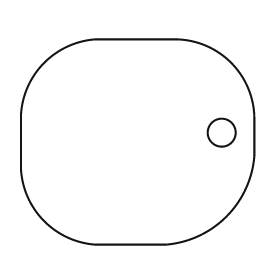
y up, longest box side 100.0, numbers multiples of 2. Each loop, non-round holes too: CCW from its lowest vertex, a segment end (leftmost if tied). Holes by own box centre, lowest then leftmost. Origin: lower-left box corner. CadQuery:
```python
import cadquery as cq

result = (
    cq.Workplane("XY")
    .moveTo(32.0, 0.0)
    .lineTo(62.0, 0.0)
    .threePointArc((88.0, 12.0), (100.0, 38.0))
    .lineTo(100.0, 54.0)
    .threePointArc((90.0, 78.0), (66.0, 88.0))
    .lineTo(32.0, 88.0)
    .threePointArc((10.0, 78.0), (0.0, 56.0))
    .lineTo(0.0, 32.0)
    .threePointArc((10.0, 10.0), (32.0, 0.0))
    .close()
    .moveTo(86.0, 48.0)
    .circle(6.0)
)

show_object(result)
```